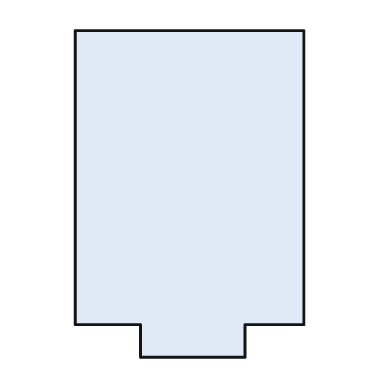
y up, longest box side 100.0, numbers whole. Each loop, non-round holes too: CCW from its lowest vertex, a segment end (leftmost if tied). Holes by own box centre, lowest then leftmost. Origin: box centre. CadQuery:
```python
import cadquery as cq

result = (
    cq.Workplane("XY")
    .moveTo(-15.0, -50.0)
    .lineTo(17.0, -50.0)
    .lineTo(17.0, -40.0)
    .lineTo(35.0, -40.0)
    .lineTo(35.0, 50.0)
    .lineTo(-35.0, 50.0)
    .lineTo(-35.0, -40.0)
    .lineTo(-15.0, -40.0)
    .close()
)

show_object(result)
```